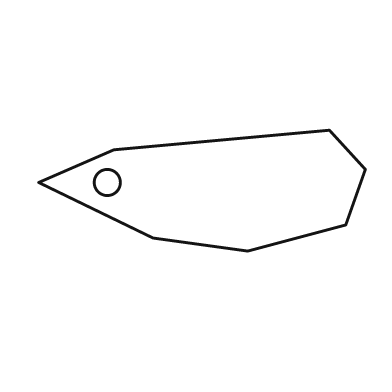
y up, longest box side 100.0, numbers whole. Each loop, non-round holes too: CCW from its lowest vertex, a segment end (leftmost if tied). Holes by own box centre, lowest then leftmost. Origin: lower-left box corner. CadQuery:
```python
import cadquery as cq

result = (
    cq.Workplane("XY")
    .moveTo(64.0, 0.0)
    .lineTo(94.0, 8.0)
    .lineTo(100.0, 25.0)
    .lineTo(89.0, 37.0)
    .lineTo(23.0, 31.0)
    .lineTo(0.0, 21.0)
    .lineTo(35.0, 4.0)
    .close()
    .moveTo(21.0, 21.0)
    .circle(4.0)
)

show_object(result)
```